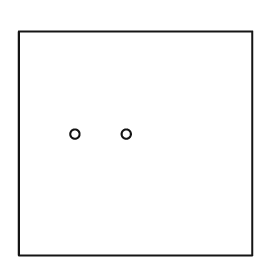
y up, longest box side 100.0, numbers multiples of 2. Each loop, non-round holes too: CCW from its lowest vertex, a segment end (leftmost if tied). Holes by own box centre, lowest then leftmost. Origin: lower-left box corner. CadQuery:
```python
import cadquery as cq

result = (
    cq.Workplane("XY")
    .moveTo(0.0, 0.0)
    .lineTo(100.0, 0.0)
    .lineTo(100.0, 96.0)
    .lineTo(0.0, 96.0)
    .close()
    .moveTo(24.0, 52.0)
    .circle(2.0)
    .moveTo(46.0, 52.0)
    .circle(2.0)
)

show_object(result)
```